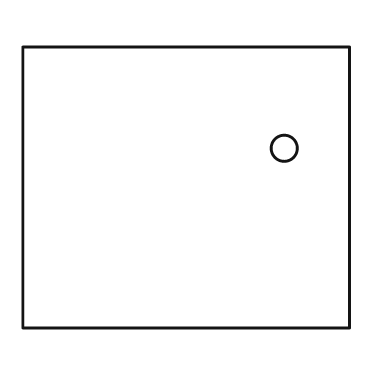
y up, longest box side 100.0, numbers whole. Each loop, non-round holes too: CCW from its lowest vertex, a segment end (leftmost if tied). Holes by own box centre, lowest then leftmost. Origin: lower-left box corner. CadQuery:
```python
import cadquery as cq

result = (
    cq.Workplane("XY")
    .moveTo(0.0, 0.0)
    .lineTo(100.0, 0.0)
    .lineTo(100.0, 86.0)
    .lineTo(0.0, 86.0)
    .close()
    .moveTo(80.0, 55.0)
    .circle(4.0)
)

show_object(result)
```